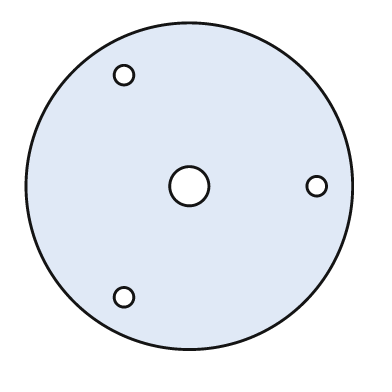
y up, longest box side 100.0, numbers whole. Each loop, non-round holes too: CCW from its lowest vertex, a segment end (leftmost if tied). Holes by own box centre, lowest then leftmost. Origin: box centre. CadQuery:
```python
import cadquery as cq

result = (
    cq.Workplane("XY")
    .moveTo(0.0, 0.0)
    .circle(50.0)
    .moveTo(-20.0, -34.0)
    .circle(3.0)
    .moveTo(0.0, 0.0)
    .circle(6.0)
    .moveTo(39.0, 0.0)
    .circle(3.0)
    .moveTo(-20.0, 34.0)
    .circle(3.0)
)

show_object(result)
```